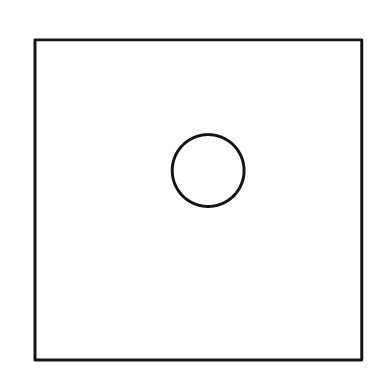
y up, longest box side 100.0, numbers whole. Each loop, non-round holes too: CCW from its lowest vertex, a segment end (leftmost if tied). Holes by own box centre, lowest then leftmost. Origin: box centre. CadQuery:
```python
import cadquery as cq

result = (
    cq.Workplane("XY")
    .moveTo(-50.0, -49.0)
    .lineTo(50.0, -49.0)
    .lineTo(50.0, 49.0)
    .lineTo(-50.0, 49.0)
    .close()
    .moveTo(3.0, 9.0)
    .circle(11.0)
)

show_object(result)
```